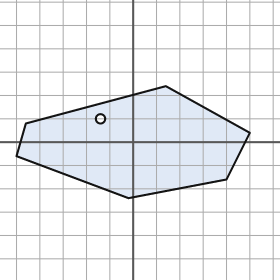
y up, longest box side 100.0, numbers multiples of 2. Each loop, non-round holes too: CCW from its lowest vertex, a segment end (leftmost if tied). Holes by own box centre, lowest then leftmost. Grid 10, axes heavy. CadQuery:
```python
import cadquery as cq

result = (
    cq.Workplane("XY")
    .moveTo(-2.0, -24.0)
    .lineTo(40.0, -16.0)
    .lineTo(50.0, 4.0)
    .lineTo(14.0, 24.0)
    .lineTo(-46.0, 8.0)
    .lineTo(-50.0, -6.0)
    .close()
    .moveTo(-14.0, 10.0)
    .circle(2.0)
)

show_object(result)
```